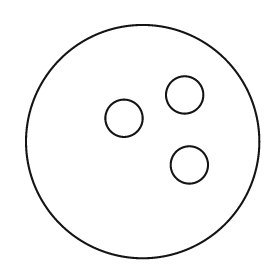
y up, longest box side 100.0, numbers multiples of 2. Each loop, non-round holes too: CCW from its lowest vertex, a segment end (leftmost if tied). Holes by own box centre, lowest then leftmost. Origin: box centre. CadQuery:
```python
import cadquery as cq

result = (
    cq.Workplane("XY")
    .moveTo(0.0, 0.0)
    .circle(50.0)
    .moveTo(20.0, -10.0)
    .circle(8.0)
    .moveTo(-8.0, 10.0)
    .circle(8.0)
    .moveTo(18.0, 20.0)
    .circle(8.0)
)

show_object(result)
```